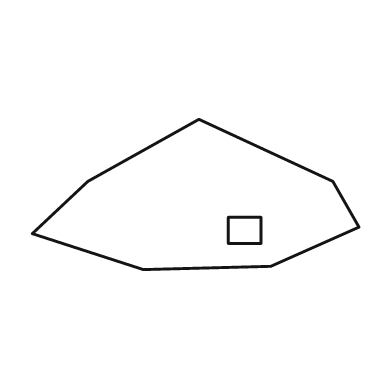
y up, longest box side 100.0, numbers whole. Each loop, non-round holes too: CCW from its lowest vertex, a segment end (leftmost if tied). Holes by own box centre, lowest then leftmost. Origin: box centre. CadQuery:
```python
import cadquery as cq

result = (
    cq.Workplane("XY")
    .moveTo(-16.0, -23.0)
    .lineTo(23.0, -22.0)
    .lineTo(50.0, -10.0)
    .lineTo(42.0, 4.0)
    .lineTo(1.0, 23.0)
    .lineTo(-33.0, 4.0)
    .lineTo(-50.0, -12.0)
    .close()
    .moveTo(10.0, -15.0)
    .lineTo(20.0, -15.0)
    .lineTo(20.0, -7.0)
    .lineTo(10.0, -7.0)
    .close()
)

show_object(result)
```